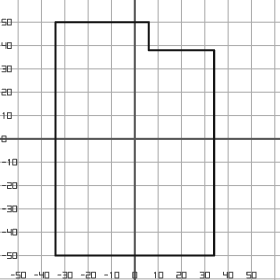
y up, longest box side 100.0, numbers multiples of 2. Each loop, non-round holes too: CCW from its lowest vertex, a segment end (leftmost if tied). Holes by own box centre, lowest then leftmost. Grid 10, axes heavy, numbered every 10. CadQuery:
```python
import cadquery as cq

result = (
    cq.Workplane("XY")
    .moveTo(-34.0, -50.0)
    .lineTo(34.0, -50.0)
    .lineTo(34.0, 38.0)
    .lineTo(6.0, 38.0)
    .lineTo(6.0, 50.0)
    .lineTo(-34.0, 50.0)
    .close()
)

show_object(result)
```